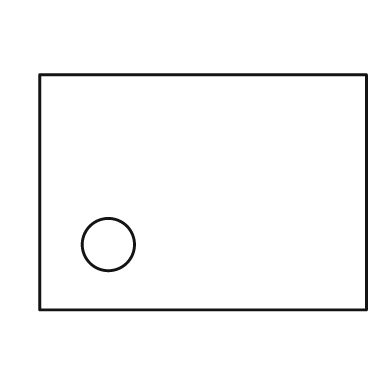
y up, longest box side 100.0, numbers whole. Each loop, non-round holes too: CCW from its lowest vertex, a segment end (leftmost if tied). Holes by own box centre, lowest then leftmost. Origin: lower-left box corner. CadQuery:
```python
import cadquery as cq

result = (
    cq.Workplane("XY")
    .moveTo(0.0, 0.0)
    .lineTo(100.0, 0.0)
    .lineTo(100.0, 72.0)
    .lineTo(0.0, 72.0)
    .close()
    .moveTo(21.0, 20.0)
    .circle(8.0)
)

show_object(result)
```